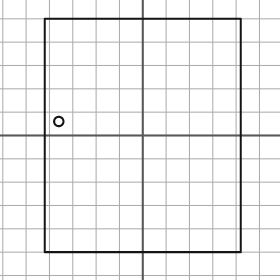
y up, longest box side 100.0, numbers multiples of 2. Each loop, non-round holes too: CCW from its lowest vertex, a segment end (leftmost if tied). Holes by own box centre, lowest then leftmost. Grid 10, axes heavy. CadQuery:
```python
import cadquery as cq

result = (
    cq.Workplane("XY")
    .moveTo(-42.0, -50.0)
    .lineTo(42.0, -50.0)
    .lineTo(42.0, 50.0)
    .lineTo(-42.0, 50.0)
    .close()
    .moveTo(-36.0, 6.0)
    .circle(2.0)
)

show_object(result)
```